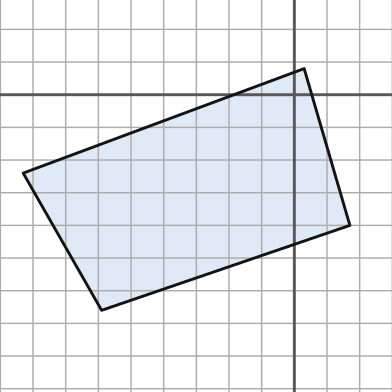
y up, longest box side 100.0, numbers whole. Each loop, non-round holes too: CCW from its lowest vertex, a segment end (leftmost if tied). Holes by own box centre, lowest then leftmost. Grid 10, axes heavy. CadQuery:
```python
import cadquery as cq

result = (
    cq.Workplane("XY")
    .moveTo(-59.0, -66.0)
    .lineTo(17.0, -40.0)
    .lineTo(3.0, 8.0)
    .lineTo(-83.0, -24.0)
    .close()
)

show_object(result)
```